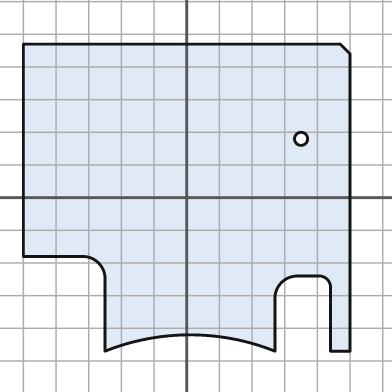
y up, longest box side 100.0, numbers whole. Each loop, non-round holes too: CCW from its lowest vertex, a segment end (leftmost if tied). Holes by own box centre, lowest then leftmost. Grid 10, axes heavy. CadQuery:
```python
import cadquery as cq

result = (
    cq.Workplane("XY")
    .moveTo(-25.0, -47.0)
    .threePointArc((1.0, -42.0), (27.0, -47.0))
    .lineTo(27.0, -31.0)
    .threePointArc((29.0, -26.0), (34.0, -24.0))
    .lineTo(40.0, -24.0)
    .threePointArc((43.0, -25.0), (44.0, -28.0))
    .lineTo(44.0, -47.0)
    .lineTo(50.0, -47.0)
    .lineTo(50.0, 44.0)
    .lineTo(47.0, 47.0)
    .lineTo(-50.0, 47.0)
    .lineTo(-50.0, -18.0)
    .lineTo(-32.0, -18.0)
    .threePointArc((-27.0, -20.0), (-25.0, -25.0))
    .close()
    .moveTo(35.0, 18.0)
    .circle(2.0)
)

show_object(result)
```